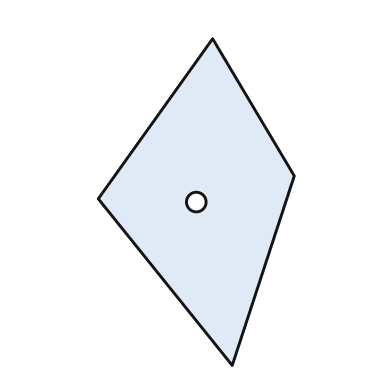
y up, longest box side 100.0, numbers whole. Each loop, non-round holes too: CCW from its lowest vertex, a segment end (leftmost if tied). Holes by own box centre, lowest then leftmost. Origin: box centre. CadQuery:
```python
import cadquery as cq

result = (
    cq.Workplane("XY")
    .moveTo(11.0, -50.0)
    .lineTo(30.0, 8.0)
    .lineTo(5.0, 50.0)
    .lineTo(-30.0, 1.0)
    .close()
    .moveTo(0.0, 0.0)
    .circle(3.0)
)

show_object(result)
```